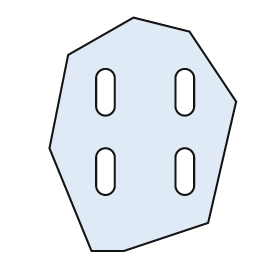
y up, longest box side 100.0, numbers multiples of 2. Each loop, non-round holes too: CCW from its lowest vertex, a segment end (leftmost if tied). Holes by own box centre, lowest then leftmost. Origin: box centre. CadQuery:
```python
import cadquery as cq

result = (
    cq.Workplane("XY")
    .moveTo(-22.0, -50.0)
    .lineTo(-8.0, -50.0)
    .lineTo(28.0, -38.0)
    .lineTo(40.0, 14.0)
    .lineTo(20.0, 44.0)
    .lineTo(-4.0, 50.0)
    .lineTo(-32.0, 34.0)
    .lineTo(-40.0, -6.0)
    .close()
    .moveTo(-20.0, -22.0)
    .threePointArc((-16.0, -26.0), (-12.0, -22.0))
    .lineTo(-12.0, -10.0)
    .threePointArc((-16.0, -6.0), (-20.0, -10.0))
    .close()
    .moveTo(14.0, -22.0)
    .threePointArc((18.0, -26.0), (22.0, -22.0))
    .lineTo(22.0, -10.0)
    .threePointArc((18.0, -6.0), (14.0, -10.0))
    .close()
    .moveTo(-20.0, 12.0)
    .threePointArc((-16.0, 8.0), (-12.0, 12.0))
    .lineTo(-12.0, 24.0)
    .threePointArc((-16.0, 28.0), (-20.0, 24.0))
    .close()
    .moveTo(14.0, 12.0)
    .threePointArc((18.0, 8.0), (22.0, 12.0))
    .lineTo(22.0, 24.0)
    .threePointArc((18.0, 28.0), (14.0, 24.0))
    .close()
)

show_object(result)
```